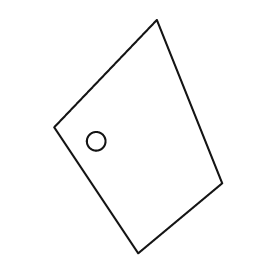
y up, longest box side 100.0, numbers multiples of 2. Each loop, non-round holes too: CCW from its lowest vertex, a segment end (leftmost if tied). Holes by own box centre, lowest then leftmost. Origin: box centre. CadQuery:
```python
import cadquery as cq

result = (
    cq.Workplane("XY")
    .moveTo(0.0, -50.0)
    .lineTo(36.0, -20.0)
    .lineTo(8.0, 50.0)
    .lineTo(-36.0, 4.0)
    .close()
    .moveTo(-18.0, -2.0)
    .circle(4.0)
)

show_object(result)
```